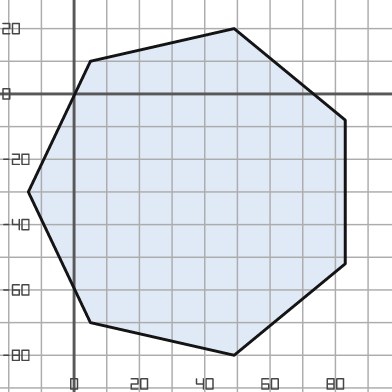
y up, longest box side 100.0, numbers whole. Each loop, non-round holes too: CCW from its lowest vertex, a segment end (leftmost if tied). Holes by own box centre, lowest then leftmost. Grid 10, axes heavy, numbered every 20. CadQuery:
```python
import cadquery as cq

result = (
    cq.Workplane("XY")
    .moveTo(49.0, -80.0)
    .lineTo(83.0, -52.0)
    .lineTo(83.0, -8.0)
    .lineTo(49.0, 20.0)
    .lineTo(5.0, 10.0)
    .lineTo(-14.0, -30.0)
    .lineTo(5.0, -70.0)
    .close()
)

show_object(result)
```